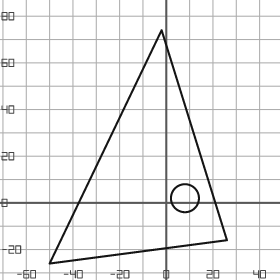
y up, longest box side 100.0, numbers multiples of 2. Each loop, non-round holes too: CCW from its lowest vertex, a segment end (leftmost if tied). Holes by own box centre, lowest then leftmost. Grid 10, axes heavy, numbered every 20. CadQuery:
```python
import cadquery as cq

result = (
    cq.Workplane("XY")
    .moveTo(-50.0, -26.0)
    .lineTo(26.0, -16.0)
    .lineTo(-2.0, 74.0)
    .close()
    .moveTo(8.0, 2.0)
    .circle(6.0)
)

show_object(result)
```